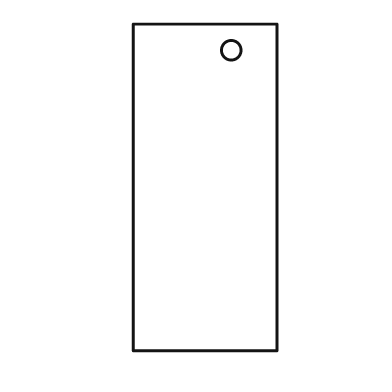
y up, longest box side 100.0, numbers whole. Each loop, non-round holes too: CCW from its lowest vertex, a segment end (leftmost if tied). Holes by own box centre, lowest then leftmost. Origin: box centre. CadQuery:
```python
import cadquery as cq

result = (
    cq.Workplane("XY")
    .moveTo(-22.0, -50.0)
    .lineTo(22.0, -50.0)
    .lineTo(22.0, 50.0)
    .lineTo(-22.0, 50.0)
    .close()
    .moveTo(8.0, 42.0)
    .circle(3.0)
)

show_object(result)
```